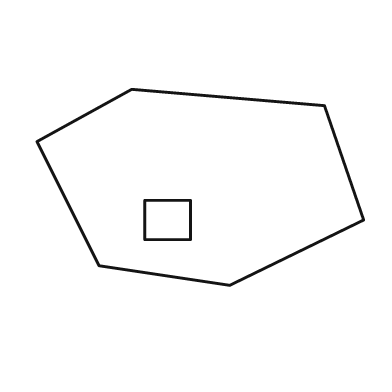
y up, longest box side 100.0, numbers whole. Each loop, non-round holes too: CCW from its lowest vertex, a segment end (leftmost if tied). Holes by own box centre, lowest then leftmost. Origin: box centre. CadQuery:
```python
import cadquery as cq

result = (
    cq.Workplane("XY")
    .moveTo(9.0, -30.0)
    .lineTo(50.0, -10.0)
    .lineTo(38.0, 25.0)
    .lineTo(-21.0, 30.0)
    .lineTo(-50.0, 14.0)
    .lineTo(-31.0, -24.0)
    .close()
    .moveTo(-17.0, -16.0)
    .lineTo(-3.0, -16.0)
    .lineTo(-3.0, -4.0)
    .lineTo(-17.0, -4.0)
    .close()
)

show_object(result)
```